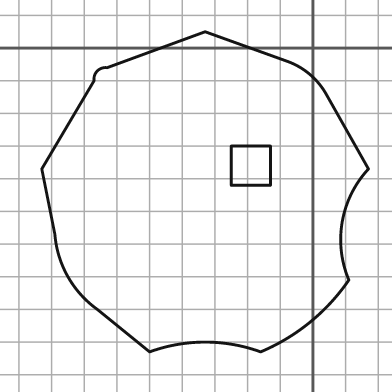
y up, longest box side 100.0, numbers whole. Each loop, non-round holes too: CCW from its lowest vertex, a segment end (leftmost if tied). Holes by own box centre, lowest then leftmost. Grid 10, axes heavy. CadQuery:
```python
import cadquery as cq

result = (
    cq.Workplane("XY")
    .moveTo(-50.0, -93.0)
    .threePointArc((-33.0, -90.0), (-16.0, -93.0))
    .threePointArc((-1.0, -84.0), (11.0, -71.0))
    .threePointArc((9.0, -53.0), (17.0, -37.0))
    .lineTo(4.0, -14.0)
    .threePointArc((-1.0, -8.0), (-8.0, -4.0))
    .lineTo(-33.0, 5.0)
    .lineTo(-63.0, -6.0)
    .threePointArc((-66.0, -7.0), (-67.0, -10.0))
    .lineTo(-83.0, -37.0)
    .lineTo(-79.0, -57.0)
    .threePointArc((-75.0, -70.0), (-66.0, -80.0))
    .close()
    .moveTo(-25.0, -42.0)
    .lineTo(-13.0, -42.0)
    .lineTo(-13.0, -30.0)
    .lineTo(-25.0, -30.0)
    .close()
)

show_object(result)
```